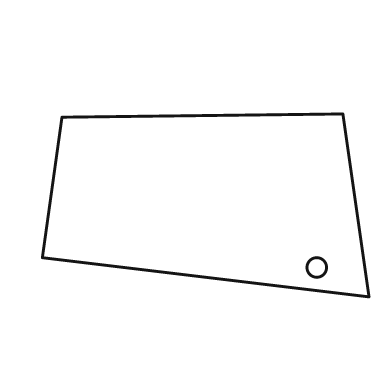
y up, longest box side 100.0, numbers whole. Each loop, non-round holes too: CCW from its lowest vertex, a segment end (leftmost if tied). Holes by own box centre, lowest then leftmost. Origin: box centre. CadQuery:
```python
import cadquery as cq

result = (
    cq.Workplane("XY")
    .moveTo(50.0, -28.0)
    .lineTo(42.0, 28.0)
    .lineTo(-44.0, 27.0)
    .lineTo(-50.0, -16.0)
    .close()
    .moveTo(34.0, -19.0)
    .circle(3.0)
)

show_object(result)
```